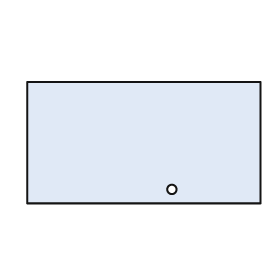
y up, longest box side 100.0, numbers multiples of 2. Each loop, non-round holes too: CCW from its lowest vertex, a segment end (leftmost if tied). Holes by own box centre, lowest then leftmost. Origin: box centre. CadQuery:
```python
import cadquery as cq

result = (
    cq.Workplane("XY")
    .moveTo(-50.0, -26.0)
    .lineTo(50.0, -26.0)
    .lineTo(50.0, 26.0)
    .lineTo(-50.0, 26.0)
    .close()
    .moveTo(12.0, -20.0)
    .circle(2.0)
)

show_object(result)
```